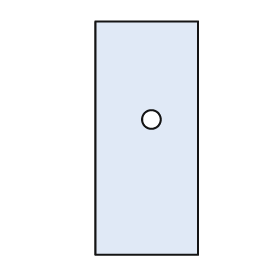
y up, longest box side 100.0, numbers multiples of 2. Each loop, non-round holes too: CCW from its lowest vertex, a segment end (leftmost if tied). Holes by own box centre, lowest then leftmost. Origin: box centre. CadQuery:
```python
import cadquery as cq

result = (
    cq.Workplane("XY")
    .moveTo(-22.0, -50.0)
    .lineTo(22.0, -50.0)
    .lineTo(22.0, 50.0)
    .lineTo(-22.0, 50.0)
    .close()
    .moveTo(2.0, 8.0)
    .circle(4.0)
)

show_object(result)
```